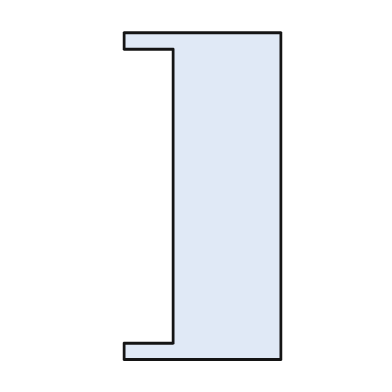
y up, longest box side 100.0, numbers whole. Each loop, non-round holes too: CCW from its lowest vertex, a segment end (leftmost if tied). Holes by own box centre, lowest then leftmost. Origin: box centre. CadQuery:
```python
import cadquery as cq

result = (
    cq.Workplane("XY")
    .moveTo(-24.0, -50.0)
    .lineTo(24.0, -50.0)
    .lineTo(24.0, 50.0)
    .lineTo(-24.0, 50.0)
    .lineTo(-24.0, 45.0)
    .lineTo(-9.0, 45.0)
    .lineTo(-9.0, -45.0)
    .lineTo(-24.0, -45.0)
    .close()
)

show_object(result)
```